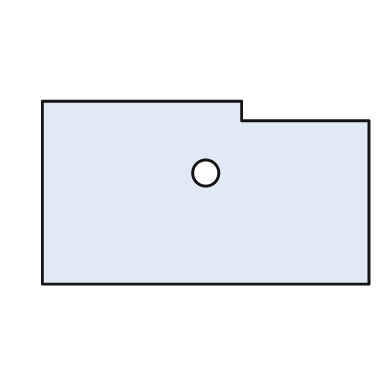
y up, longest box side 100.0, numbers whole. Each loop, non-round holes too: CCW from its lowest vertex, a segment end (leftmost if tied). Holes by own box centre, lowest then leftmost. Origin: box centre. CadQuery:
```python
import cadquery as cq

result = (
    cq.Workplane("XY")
    .moveTo(-50.0, -28.0)
    .lineTo(50.0, -28.0)
    .lineTo(50.0, 22.0)
    .lineTo(11.0, 22.0)
    .lineTo(11.0, 28.0)
    .lineTo(-50.0, 28.0)
    .close()
    .moveTo(0.0, 6.0)
    .circle(4.0)
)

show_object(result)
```